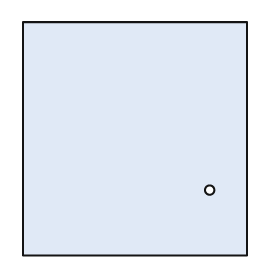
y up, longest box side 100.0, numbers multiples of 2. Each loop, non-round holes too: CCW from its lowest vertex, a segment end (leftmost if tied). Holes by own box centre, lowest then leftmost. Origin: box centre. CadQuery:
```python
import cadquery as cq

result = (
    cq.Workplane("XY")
    .moveTo(-48.0, -50.0)
    .lineTo(48.0, -50.0)
    .lineTo(48.0, 50.0)
    .lineTo(-48.0, 50.0)
    .close()
    .moveTo(32.0, -22.0)
    .circle(2.0)
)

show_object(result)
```